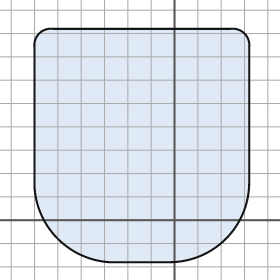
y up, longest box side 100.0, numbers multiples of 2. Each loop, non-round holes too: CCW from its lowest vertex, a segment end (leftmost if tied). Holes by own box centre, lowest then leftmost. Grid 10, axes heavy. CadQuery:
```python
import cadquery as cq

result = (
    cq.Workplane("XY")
    .moveTo(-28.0, -18.0)
    .lineTo(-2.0, -18.0)
    .threePointArc((22.0, -8.0), (32.0, 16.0))
    .lineTo(32.0, 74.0)
    .threePointArc((30.0, 80.0), (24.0, 82.0))
    .lineTo(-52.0, 82.0)
    .threePointArc((-58.0, 80.0), (-60.0, 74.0))
    .lineTo(-60.0, 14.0)
    .threePointArc((-50.0, -8.0), (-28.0, -18.0))
    .close()
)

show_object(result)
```